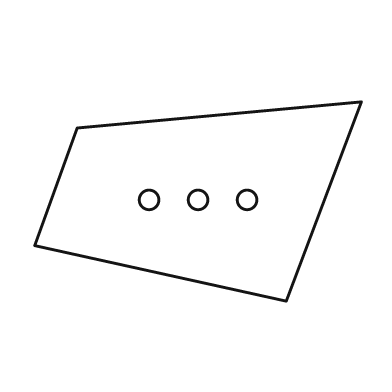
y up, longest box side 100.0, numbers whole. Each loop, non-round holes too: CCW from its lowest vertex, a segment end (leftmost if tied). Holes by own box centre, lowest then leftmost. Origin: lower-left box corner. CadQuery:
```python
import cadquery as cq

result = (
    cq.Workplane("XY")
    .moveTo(77.0, 0.0)
    .lineTo(100.0, 61.0)
    .lineTo(13.0, 53.0)
    .lineTo(0.0, 17.0)
    .close()
    .moveTo(35.0, 31.0)
    .circle(3.0)
    .moveTo(50.0, 31.0)
    .circle(3.0)
    .moveTo(65.0, 31.0)
    .circle(3.0)
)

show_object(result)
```